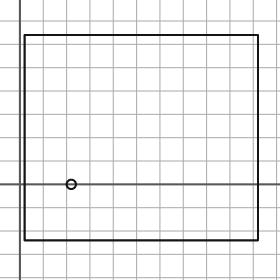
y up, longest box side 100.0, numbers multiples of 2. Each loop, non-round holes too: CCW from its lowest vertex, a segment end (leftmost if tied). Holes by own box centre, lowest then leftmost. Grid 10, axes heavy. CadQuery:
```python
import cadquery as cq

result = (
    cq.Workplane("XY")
    .moveTo(2.0, -24.0)
    .lineTo(102.0, -24.0)
    .lineTo(102.0, 64.0)
    .lineTo(2.0, 64.0)
    .close()
    .moveTo(22.0, 0.0)
    .circle(2.0)
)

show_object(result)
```